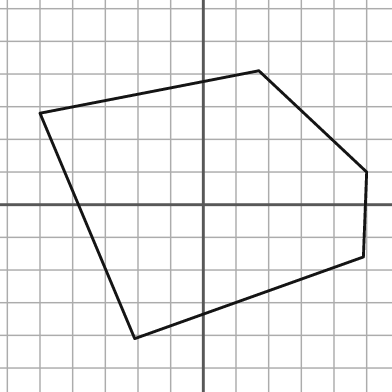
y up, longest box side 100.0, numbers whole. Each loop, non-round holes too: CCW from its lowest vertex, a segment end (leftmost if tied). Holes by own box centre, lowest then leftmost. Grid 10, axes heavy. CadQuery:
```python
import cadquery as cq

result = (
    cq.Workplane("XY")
    .moveTo(-21.0, -41.0)
    .lineTo(49.0, -16.0)
    .lineTo(50.0, 10.0)
    .lineTo(17.0, 41.0)
    .lineTo(-50.0, 28.0)
    .close()
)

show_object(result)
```